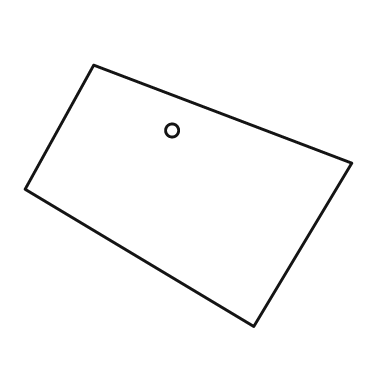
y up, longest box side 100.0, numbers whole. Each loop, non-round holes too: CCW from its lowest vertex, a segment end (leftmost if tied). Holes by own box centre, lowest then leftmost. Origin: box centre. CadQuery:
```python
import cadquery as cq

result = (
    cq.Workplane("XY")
    .moveTo(20.0, -40.0)
    .lineTo(50.0, 10.0)
    .lineTo(-29.0, 40.0)
    .lineTo(-50.0, 2.0)
    .close()
    .moveTo(-5.0, 20.0)
    .circle(2.0)
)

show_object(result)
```